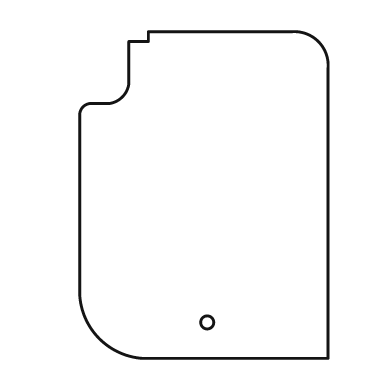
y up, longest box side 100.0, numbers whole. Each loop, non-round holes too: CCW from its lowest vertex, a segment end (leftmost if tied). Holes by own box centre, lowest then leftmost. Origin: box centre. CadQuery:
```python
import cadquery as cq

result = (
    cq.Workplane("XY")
    .moveTo(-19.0, -50.0)
    .lineTo(38.0, -50.0)
    .lineTo(38.0, 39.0)
    .threePointArc((35.0, 47.0), (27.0, 50.0))
    .lineTo(-17.0, 50.0)
    .lineTo(-17.0, 47.0)
    .lineTo(-23.0, 47.0)
    .lineTo(-23.0, 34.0)
    .threePointArc((-25.0, 30.0), (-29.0, 28.0))
    .lineTo(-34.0, 28.0)
    .threePointArc((-37.0, 27.0), (-38.0, 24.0))
    .lineTo(-38.0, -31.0)
    .threePointArc((-32.0, -44.0), (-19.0, -50.0))
    .close()
    .moveTo(1.0, -39.0)
    .circle(2.0)
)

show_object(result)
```